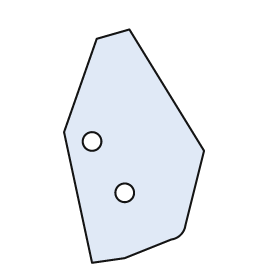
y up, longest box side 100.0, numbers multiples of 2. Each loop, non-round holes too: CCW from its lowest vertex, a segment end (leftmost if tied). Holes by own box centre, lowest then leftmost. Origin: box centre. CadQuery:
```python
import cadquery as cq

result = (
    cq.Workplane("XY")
    .moveTo(-18.0, -50.0)
    .lineTo(-4.0, -48.0)
    .lineTo(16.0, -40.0)
    .threePointArc((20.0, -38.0), (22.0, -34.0))
    .lineTo(30.0, -2.0)
    .lineTo(-2.0, 50.0)
    .lineTo(-16.0, 46.0)
    .lineTo(-30.0, 6.0)
    .close()
    .moveTo(-4.0, -20.0)
    .circle(4.0)
    .moveTo(-18.0, 2.0)
    .circle(4.0)
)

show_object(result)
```